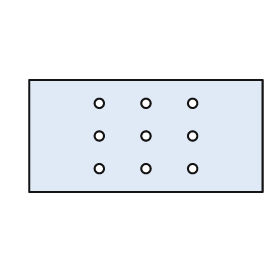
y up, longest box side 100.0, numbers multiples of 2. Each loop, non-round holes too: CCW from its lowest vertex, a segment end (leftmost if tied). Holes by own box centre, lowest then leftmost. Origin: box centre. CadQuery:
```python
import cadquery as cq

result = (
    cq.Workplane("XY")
    .moveTo(-50.0, -24.0)
    .lineTo(50.0, -24.0)
    .lineTo(50.0, 24.0)
    .lineTo(-50.0, 24.0)
    .close()
    .moveTo(-20.0, -14.0)
    .circle(2.0)
    .moveTo(0.0, -14.0)
    .circle(2.0)
    .moveTo(20.0, -14.0)
    .circle(2.0)
    .moveTo(-20.0, 0.0)
    .circle(2.0)
    .moveTo(0.0, 0.0)
    .circle(2.0)
    .moveTo(20.0, 0.0)
    .circle(2.0)
    .moveTo(-20.0, 14.0)
    .circle(2.0)
    .moveTo(0.0, 14.0)
    .circle(2.0)
    .moveTo(20.0, 14.0)
    .circle(2.0)
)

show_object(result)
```